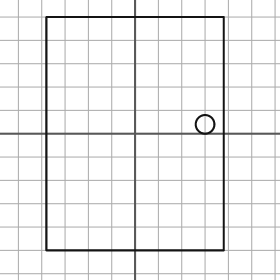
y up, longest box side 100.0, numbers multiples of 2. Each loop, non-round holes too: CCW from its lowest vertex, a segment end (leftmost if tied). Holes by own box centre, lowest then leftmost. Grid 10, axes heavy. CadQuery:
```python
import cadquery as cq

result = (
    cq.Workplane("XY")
    .moveTo(-38.0, -50.0)
    .lineTo(38.0, -50.0)
    .lineTo(38.0, 50.0)
    .lineTo(-38.0, 50.0)
    .close()
    .moveTo(30.0, 4.0)
    .circle(4.0)
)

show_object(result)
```